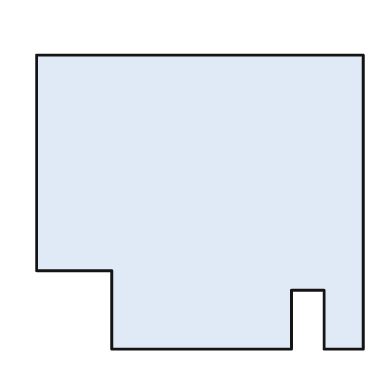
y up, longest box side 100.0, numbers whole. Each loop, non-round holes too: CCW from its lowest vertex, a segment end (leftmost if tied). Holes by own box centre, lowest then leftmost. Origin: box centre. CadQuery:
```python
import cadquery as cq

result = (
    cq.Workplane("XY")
    .moveTo(-27.0, -45.0)
    .lineTo(28.0, -45.0)
    .lineTo(28.0, -27.0)
    .lineTo(38.0, -27.0)
    .lineTo(38.0, -45.0)
    .lineTo(50.0, -45.0)
    .lineTo(50.0, 45.0)
    .lineTo(-50.0, 45.0)
    .lineTo(-50.0, -21.0)
    .lineTo(-27.0, -21.0)
    .close()
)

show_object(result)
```